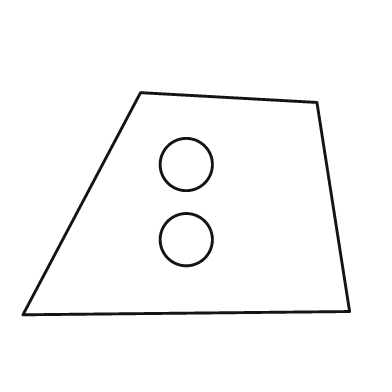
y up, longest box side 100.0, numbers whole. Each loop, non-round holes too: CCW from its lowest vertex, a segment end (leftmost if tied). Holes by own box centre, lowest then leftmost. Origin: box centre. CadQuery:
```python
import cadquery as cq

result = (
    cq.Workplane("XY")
    .moveTo(-50.0, -34.0)
    .lineTo(50.0, -33.0)
    .lineTo(40.0, 31.0)
    .lineTo(-14.0, 34.0)
    .close()
    .moveTo(0.0, -11.0)
    .circle(8.0)
    .moveTo(0.0, 12.0)
    .circle(8.0)
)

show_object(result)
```